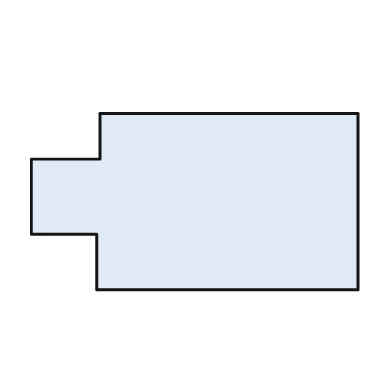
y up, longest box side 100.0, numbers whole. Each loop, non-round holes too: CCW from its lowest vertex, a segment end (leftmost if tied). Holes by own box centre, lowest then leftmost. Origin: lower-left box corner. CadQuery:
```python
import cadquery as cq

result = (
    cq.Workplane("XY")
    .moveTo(20.0, 0.0)
    .lineTo(100.0, 0.0)
    .lineTo(100.0, 54.0)
    .lineTo(21.0, 54.0)
    .lineTo(21.0, 40.0)
    .lineTo(0.0, 40.0)
    .lineTo(0.0, 17.0)
    .lineTo(20.0, 17.0)
    .close()
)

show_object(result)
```